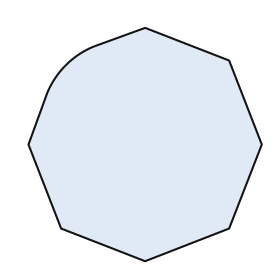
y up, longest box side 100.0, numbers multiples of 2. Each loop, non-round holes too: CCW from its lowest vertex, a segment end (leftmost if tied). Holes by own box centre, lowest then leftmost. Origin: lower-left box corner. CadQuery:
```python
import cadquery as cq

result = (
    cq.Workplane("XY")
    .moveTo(50.0, 0.0)
    .lineTo(86.0, 14.0)
    .lineTo(100.0, 50.0)
    .lineTo(86.0, 86.0)
    .lineTo(50.0, 100.0)
    .lineTo(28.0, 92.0)
    .threePointArc((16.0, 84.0), (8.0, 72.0))
    .lineTo(0.0, 50.0)
    .lineTo(14.0, 14.0)
    .close()
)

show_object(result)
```